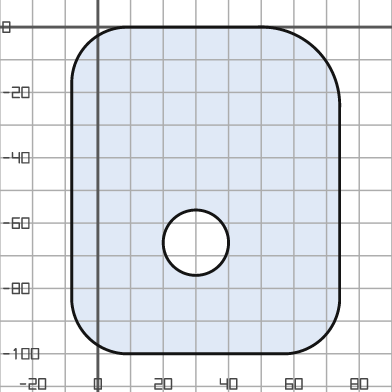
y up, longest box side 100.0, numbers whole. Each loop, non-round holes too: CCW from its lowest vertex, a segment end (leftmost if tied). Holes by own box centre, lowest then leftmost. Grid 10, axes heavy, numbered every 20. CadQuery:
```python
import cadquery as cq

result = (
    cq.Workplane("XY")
    .moveTo(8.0, -100.0)
    .lineTo(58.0, -100.0)
    .threePointArc((69.0, -95.0), (74.0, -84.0))
    .lineTo(74.0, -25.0)
    .threePointArc((67.0, -7.0), (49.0, 0.0))
    .lineTo(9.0, 0.0)
    .threePointArc((-3.0, -5.0), (-8.0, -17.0))
    .lineTo(-8.0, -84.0)
    .threePointArc((-3.0, -95.0), (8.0, -100.0))
    .close()
    .moveTo(30.0, -66.0)
    .circle(10.0)
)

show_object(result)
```